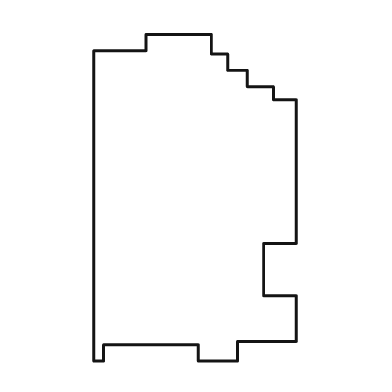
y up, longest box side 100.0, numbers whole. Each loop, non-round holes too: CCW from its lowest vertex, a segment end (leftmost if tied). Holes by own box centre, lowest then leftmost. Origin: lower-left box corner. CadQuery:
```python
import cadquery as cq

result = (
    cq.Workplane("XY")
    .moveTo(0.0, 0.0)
    .lineTo(3.0, 0.0)
    .lineTo(3.0, 5.0)
    .lineTo(32.0, 5.0)
    .lineTo(32.0, 0.0)
    .lineTo(44.0, 0.0)
    .lineTo(44.0, 6.0)
    .lineTo(62.0, 6.0)
    .lineTo(62.0, 20.0)
    .lineTo(52.0, 20.0)
    .lineTo(52.0, 36.0)
    .lineTo(62.0, 36.0)
    .lineTo(62.0, 80.0)
    .lineTo(55.0, 80.0)
    .lineTo(55.0, 84.0)
    .lineTo(47.0, 84.0)
    .lineTo(47.0, 89.0)
    .lineTo(41.0, 89.0)
    .lineTo(41.0, 94.0)
    .lineTo(36.0, 94.0)
    .lineTo(36.0, 100.0)
    .lineTo(16.0, 100.0)
    .lineTo(16.0, 95.0)
    .lineTo(0.0, 95.0)
    .close()
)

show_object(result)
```